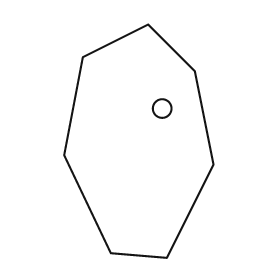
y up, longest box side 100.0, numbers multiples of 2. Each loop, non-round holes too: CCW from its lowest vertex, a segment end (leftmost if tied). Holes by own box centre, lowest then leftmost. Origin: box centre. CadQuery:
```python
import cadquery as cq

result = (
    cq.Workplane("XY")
    .moveTo(12.0, -50.0)
    .lineTo(32.0, -10.0)
    .lineTo(24.0, 30.0)
    .lineTo(4.0, 50.0)
    .lineTo(-24.0, 36.0)
    .lineTo(-32.0, -6.0)
    .lineTo(-12.0, -48.0)
    .close()
    .moveTo(10.0, 14.0)
    .circle(4.0)
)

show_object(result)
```